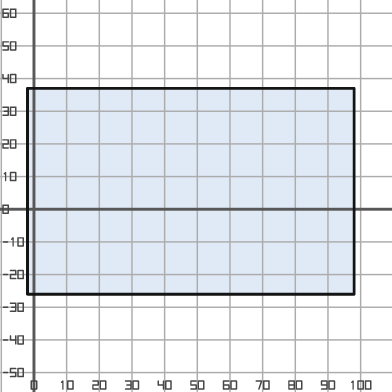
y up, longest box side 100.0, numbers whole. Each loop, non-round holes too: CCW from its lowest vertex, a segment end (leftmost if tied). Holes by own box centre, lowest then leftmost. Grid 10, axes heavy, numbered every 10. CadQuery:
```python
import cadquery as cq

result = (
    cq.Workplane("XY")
    .moveTo(-2.0, -26.0)
    .lineTo(98.0, -26.0)
    .lineTo(98.0, 37.0)
    .lineTo(-2.0, 37.0)
    .close()
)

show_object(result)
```